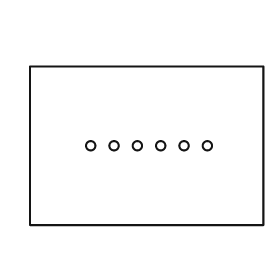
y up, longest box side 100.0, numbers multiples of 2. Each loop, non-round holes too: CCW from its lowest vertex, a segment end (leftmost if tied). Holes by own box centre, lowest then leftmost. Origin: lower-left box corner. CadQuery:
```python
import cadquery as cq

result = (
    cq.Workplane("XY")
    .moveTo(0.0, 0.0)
    .lineTo(100.0, 0.0)
    .lineTo(100.0, 68.0)
    .lineTo(0.0, 68.0)
    .close()
    .moveTo(26.0, 34.0)
    .circle(2.0)
    .moveTo(36.0, 34.0)
    .circle(2.0)
    .moveTo(46.0, 34.0)
    .circle(2.0)
    .moveTo(56.0, 34.0)
    .circle(2.0)
    .moveTo(66.0, 34.0)
    .circle(2.0)
    .moveTo(76.0, 34.0)
    .circle(2.0)
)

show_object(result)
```